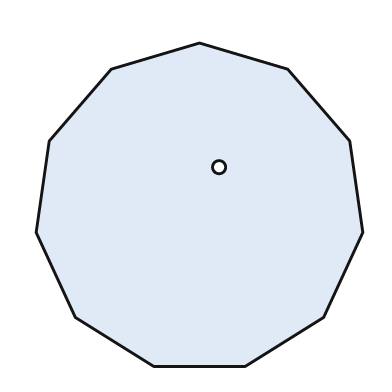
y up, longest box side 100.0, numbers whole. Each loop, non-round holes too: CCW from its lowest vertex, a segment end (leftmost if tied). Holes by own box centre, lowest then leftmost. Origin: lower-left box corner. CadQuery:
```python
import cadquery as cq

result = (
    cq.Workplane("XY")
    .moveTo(36.0, 0.0)
    .lineTo(64.0, 0.0)
    .lineTo(88.0, 15.0)
    .lineTo(100.0, 41.0)
    .lineTo(96.0, 69.0)
    .lineTo(77.0, 91.0)
    .lineTo(50.0, 99.0)
    .lineTo(23.0, 91.0)
    .lineTo(4.0, 69.0)
    .lineTo(0.0, 41.0)
    .lineTo(12.0, 15.0)
    .close()
    .moveTo(56.0, 61.0)
    .circle(2.0)
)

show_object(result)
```